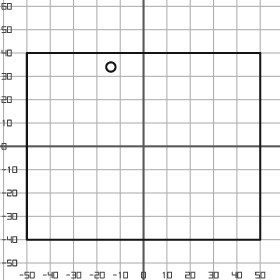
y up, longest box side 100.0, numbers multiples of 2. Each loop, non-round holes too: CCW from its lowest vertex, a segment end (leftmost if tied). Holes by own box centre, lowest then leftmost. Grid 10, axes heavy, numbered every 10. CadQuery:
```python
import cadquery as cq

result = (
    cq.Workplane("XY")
    .moveTo(-50.0, -40.0)
    .lineTo(50.0, -40.0)
    .lineTo(50.0, 40.0)
    .lineTo(-50.0, 40.0)
    .close()
    .moveTo(-14.0, 34.0)
    .circle(2.0)
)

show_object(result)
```